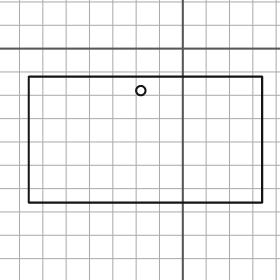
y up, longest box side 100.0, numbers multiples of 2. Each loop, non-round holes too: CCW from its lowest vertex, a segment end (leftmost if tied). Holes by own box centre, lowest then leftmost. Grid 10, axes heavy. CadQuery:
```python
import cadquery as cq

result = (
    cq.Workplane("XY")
    .moveTo(-66.0, -66.0)
    .lineTo(34.0, -66.0)
    .lineTo(34.0, -12.0)
    .lineTo(-66.0, -12.0)
    .close()
    .moveTo(-18.0, -18.0)
    .circle(2.0)
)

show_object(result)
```